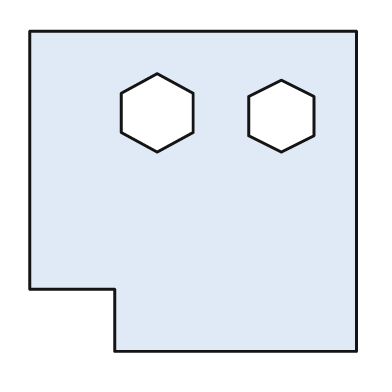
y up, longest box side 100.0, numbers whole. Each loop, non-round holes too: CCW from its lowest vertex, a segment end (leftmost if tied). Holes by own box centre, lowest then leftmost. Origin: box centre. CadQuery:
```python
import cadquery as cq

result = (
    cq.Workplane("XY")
    .moveTo(-24.0, -49.0)
    .lineTo(50.0, -49.0)
    .lineTo(50.0, 49.0)
    .lineTo(-50.0, 49.0)
    .lineTo(-50.0, -30.0)
    .lineTo(-24.0, -30.0)
    .close()
    .moveTo(27.0, 12.0)
    .lineTo(37.0, 17.0)
    .lineTo(37.0, 29.0)
    .lineTo(27.0, 34.0)
    .lineTo(17.0, 29.0)
    .lineTo(17.0, 17.0)
    .close()
    .moveTo(-11.0, 12.0)
    .lineTo(0.0, 18.0)
    .lineTo(0.0, 30.0)
    .lineTo(-11.0, 36.0)
    .lineTo(-22.0, 30.0)
    .lineTo(-22.0, 18.0)
    .close()
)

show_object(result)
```